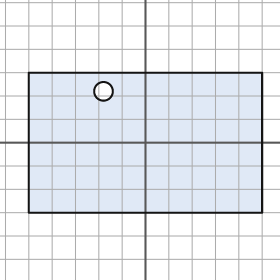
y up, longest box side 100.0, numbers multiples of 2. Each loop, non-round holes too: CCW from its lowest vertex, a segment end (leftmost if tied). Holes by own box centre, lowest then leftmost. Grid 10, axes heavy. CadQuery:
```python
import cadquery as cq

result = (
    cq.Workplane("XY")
    .moveTo(-50.0, -30.0)
    .lineTo(50.0, -30.0)
    .lineTo(50.0, 30.0)
    .lineTo(-50.0, 30.0)
    .close()
    .moveTo(-18.0, 22.0)
    .circle(4.0)
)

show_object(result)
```